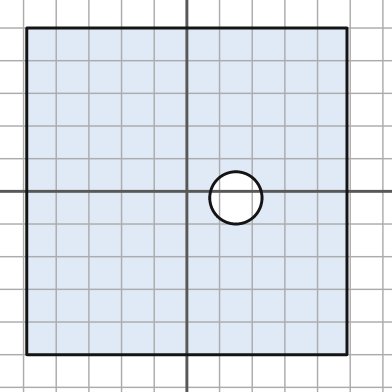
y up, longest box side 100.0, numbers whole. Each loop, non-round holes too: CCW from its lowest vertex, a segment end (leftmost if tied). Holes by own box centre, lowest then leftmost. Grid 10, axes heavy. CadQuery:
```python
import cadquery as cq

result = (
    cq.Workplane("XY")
    .moveTo(-49.0, -50.0)
    .lineTo(49.0, -50.0)
    .lineTo(49.0, 50.0)
    .lineTo(-49.0, 50.0)
    .close()
    .moveTo(15.0, -2.0)
    .circle(8.0)
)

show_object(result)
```